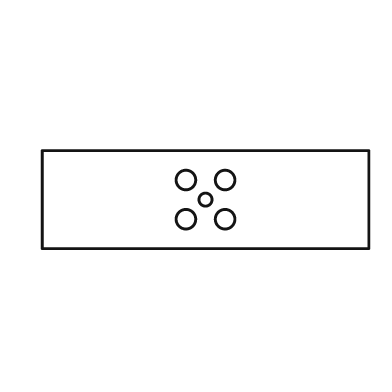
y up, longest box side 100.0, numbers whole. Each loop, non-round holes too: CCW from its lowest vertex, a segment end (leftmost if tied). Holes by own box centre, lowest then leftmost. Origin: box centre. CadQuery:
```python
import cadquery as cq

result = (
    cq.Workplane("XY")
    .moveTo(-50.0, -15.0)
    .lineTo(50.0, -15.0)
    .lineTo(50.0, 15.0)
    .lineTo(-50.0, 15.0)
    .close()
    .moveTo(-6.0, -6.0)
    .circle(3.0)
    .moveTo(6.0, -6.0)
    .circle(3.0)
    .moveTo(0.0, 0.0)
    .circle(2.0)
    .moveTo(-6.0, 6.0)
    .circle(3.0)
    .moveTo(6.0, 6.0)
    .circle(3.0)
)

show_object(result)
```